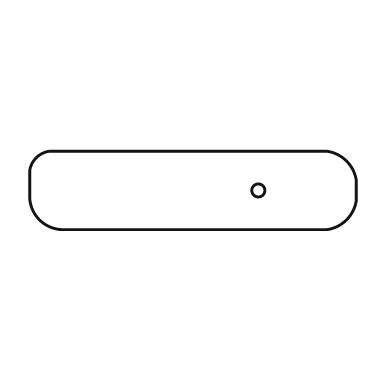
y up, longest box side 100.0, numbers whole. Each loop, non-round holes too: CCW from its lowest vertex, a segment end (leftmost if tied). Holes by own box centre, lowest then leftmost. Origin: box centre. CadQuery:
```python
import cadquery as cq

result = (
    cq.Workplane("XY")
    .moveTo(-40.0, -12.0)
    .lineTo(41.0, -12.0)
    .threePointArc((47.0, -9.0), (50.0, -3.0))
    .lineTo(50.0, 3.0)
    .threePointArc((47.0, 9.0), (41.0, 12.0))
    .lineTo(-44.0, 12.0)
    .threePointArc((-48.0, 10.0), (-50.0, 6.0))
    .lineTo(-50.0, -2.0)
    .threePointArc((-47.0, -9.0), (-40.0, -12.0))
    .close()
    .moveTo(20.0, 0.0)
    .circle(2.0)
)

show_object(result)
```